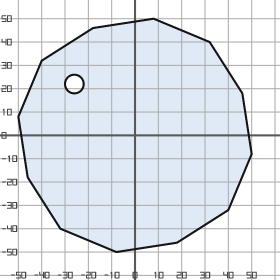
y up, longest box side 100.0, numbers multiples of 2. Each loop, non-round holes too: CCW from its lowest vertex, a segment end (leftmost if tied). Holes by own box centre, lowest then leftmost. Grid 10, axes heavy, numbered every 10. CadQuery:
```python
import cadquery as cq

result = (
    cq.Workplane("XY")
    .moveTo(-8.0, -50.0)
    .lineTo(18.0, -46.0)
    .lineTo(40.0, -32.0)
    .lineTo(50.0, -8.0)
    .lineTo(46.0, 18.0)
    .lineTo(32.0, 40.0)
    .lineTo(8.0, 50.0)
    .lineTo(-18.0, 46.0)
    .lineTo(-40.0, 32.0)
    .lineTo(-50.0, 8.0)
    .lineTo(-46.0, -18.0)
    .lineTo(-32.0, -40.0)
    .close()
    .moveTo(-26.0, 22.0)
    .circle(4.0)
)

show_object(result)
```